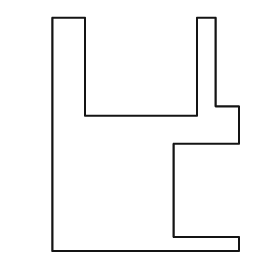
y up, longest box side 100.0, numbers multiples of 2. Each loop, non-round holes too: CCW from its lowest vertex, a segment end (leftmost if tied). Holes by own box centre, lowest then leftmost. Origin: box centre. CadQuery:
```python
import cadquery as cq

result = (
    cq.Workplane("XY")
    .moveTo(-40.0, -50.0)
    .lineTo(40.0, -50.0)
    .lineTo(40.0, -44.0)
    .lineTo(12.0, -44.0)
    .lineTo(12.0, -4.0)
    .lineTo(40.0, -4.0)
    .lineTo(40.0, 12.0)
    .lineTo(30.0, 12.0)
    .lineTo(30.0, 50.0)
    .lineTo(22.0, 50.0)
    .lineTo(22.0, 8.0)
    .lineTo(-26.0, 8.0)
    .lineTo(-26.0, 50.0)
    .lineTo(-40.0, 50.0)
    .close()
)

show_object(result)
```